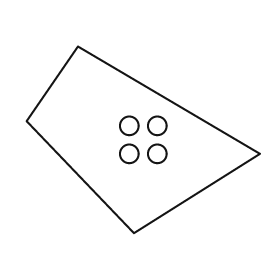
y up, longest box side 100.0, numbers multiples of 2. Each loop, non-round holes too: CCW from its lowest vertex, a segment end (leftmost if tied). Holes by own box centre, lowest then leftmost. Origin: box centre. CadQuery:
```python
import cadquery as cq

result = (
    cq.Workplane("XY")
    .moveTo(-4.0, -40.0)
    .lineTo(50.0, -6.0)
    .lineTo(-28.0, 40.0)
    .lineTo(-50.0, 8.0)
    .close()
    .moveTo(-6.0, -6.0)
    .circle(4.0)
    .moveTo(6.0, -6.0)
    .circle(4.0)
    .moveTo(-6.0, 6.0)
    .circle(4.0)
    .moveTo(6.0, 6.0)
    .circle(4.0)
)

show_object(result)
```